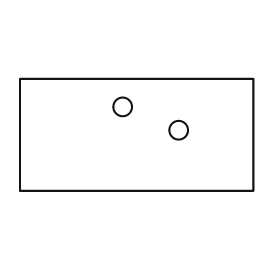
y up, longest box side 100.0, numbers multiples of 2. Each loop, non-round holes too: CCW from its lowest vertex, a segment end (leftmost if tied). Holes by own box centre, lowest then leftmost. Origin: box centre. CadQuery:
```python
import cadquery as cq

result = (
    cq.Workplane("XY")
    .moveTo(-50.0, -24.0)
    .lineTo(50.0, -24.0)
    .lineTo(50.0, 24.0)
    .lineTo(-50.0, 24.0)
    .close()
    .moveTo(18.0, 2.0)
    .circle(4.0)
    .moveTo(-6.0, 12.0)
    .circle(4.0)
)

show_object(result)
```